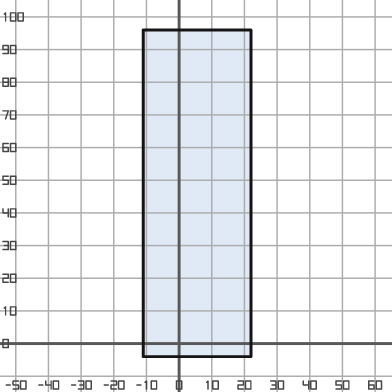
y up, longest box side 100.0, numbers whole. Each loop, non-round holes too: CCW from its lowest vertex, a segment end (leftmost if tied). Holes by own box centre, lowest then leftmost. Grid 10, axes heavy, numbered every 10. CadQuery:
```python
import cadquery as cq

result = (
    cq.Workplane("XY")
    .moveTo(-11.0, -4.0)
    .lineTo(22.0, -4.0)
    .lineTo(22.0, 96.0)
    .lineTo(-11.0, 96.0)
    .close()
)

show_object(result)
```